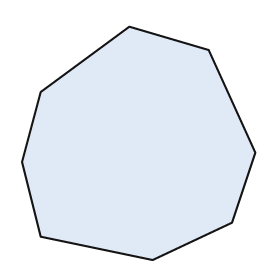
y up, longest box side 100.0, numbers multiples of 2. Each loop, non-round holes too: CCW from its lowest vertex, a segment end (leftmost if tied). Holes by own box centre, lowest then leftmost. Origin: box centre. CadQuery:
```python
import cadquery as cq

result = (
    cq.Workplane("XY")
    .moveTo(6.0, -50.0)
    .lineTo(40.0, -34.0)
    .lineTo(50.0, -4.0)
    .lineTo(30.0, 40.0)
    .lineTo(-4.0, 50.0)
    .lineTo(-42.0, 22.0)
    .lineTo(-50.0, -8.0)
    .lineTo(-42.0, -40.0)
    .close()
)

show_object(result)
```